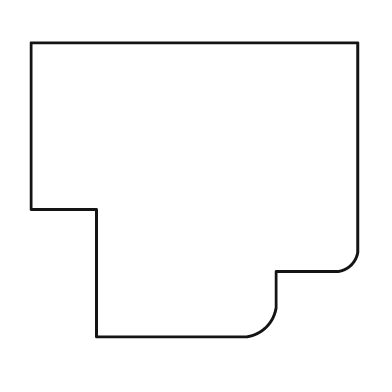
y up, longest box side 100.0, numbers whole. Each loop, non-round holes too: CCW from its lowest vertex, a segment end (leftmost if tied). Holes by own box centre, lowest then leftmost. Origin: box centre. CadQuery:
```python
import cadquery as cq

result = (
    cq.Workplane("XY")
    .moveTo(-30.0, -45.0)
    .lineTo(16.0, -45.0)
    .threePointArc((22.0, -42.0), (25.0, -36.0))
    .lineTo(25.0, -25.0)
    .lineTo(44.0, -25.0)
    .threePointArc((48.0, -23.0), (50.0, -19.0))
    .lineTo(50.0, 45.0)
    .lineTo(-50.0, 45.0)
    .lineTo(-50.0, -6.0)
    .lineTo(-30.0, -6.0)
    .close()
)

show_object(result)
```